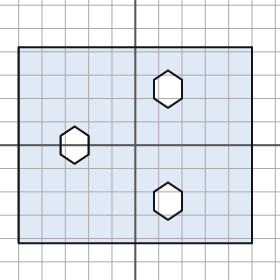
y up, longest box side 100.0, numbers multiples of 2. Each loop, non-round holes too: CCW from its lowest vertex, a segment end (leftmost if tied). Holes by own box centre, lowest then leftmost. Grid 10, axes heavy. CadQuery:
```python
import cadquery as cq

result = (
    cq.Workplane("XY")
    .moveTo(-50.0, -42.0)
    .lineTo(50.0, -42.0)
    .lineTo(50.0, 42.0)
    .lineTo(-50.0, 42.0)
    .close()
    .moveTo(14.0, -32.0)
    .lineTo(20.0, -28.0)
    .lineTo(20.0, -20.0)
    .lineTo(14.0, -16.0)
    .lineTo(8.0, -20.0)
    .lineTo(8.0, -28.0)
    .close()
    .moveTo(-26.0, -8.0)
    .lineTo(-20.0, -4.0)
    .lineTo(-20.0, 4.0)
    .lineTo(-26.0, 8.0)
    .lineTo(-32.0, 4.0)
    .lineTo(-32.0, -4.0)
    .close()
    .moveTo(14.0, 16.0)
    .lineTo(20.0, 20.0)
    .lineTo(20.0, 28.0)
    .lineTo(14.0, 32.0)
    .lineTo(8.0, 28.0)
    .lineTo(8.0, 20.0)
    .close()
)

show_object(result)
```